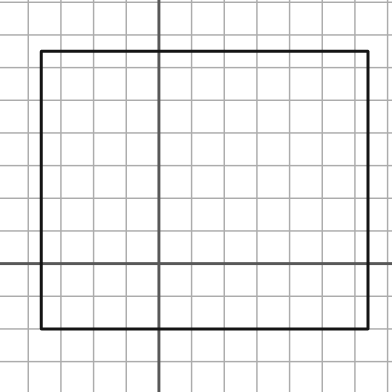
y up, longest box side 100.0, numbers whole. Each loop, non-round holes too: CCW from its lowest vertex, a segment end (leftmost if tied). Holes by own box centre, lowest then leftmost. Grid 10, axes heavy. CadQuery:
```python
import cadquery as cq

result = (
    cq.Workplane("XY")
    .moveTo(-36.0, -20.0)
    .lineTo(64.0, -20.0)
    .lineTo(64.0, 65.0)
    .lineTo(-36.0, 65.0)
    .close()
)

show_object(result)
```